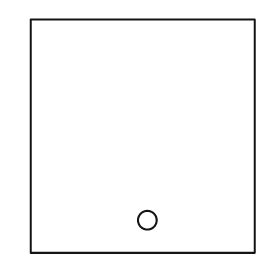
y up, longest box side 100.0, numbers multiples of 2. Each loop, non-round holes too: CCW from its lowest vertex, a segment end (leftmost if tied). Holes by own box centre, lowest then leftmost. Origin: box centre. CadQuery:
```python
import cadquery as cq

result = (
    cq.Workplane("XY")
    .moveTo(-48.0, -50.0)
    .lineTo(48.0, -50.0)
    .lineTo(48.0, 50.0)
    .lineTo(-48.0, 50.0)
    .close()
    .moveTo(2.0, -36.0)
    .circle(4.0)
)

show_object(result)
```